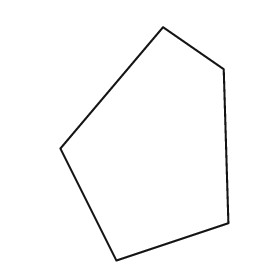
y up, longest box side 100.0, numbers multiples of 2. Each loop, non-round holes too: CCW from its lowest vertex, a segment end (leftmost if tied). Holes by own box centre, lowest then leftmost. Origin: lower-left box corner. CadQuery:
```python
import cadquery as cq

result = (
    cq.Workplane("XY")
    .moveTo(24.0, 0.0)
    .lineTo(72.0, 16.0)
    .lineTo(70.0, 82.0)
    .lineTo(44.0, 100.0)
    .lineTo(0.0, 48.0)
    .close()
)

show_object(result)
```